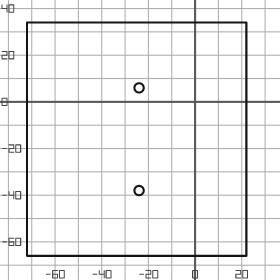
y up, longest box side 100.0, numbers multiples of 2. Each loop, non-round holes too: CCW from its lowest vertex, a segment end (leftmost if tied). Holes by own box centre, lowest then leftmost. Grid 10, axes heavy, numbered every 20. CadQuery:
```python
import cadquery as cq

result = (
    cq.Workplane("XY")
    .moveTo(-72.0, -66.0)
    .lineTo(22.0, -66.0)
    .lineTo(22.0, 34.0)
    .lineTo(-72.0, 34.0)
    .close()
    .moveTo(-24.0, -38.0)
    .circle(2.0)
    .moveTo(-24.0, 6.0)
    .circle(2.0)
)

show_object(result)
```